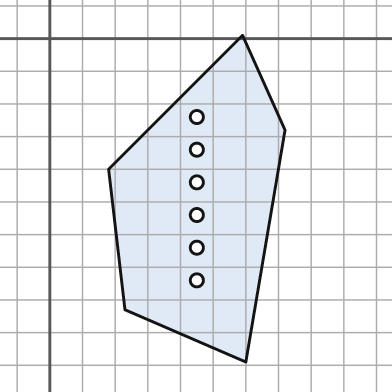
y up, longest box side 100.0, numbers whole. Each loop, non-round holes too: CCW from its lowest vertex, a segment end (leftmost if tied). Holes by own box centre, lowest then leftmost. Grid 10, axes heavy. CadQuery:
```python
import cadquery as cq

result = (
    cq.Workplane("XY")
    .moveTo(60.0, -99.0)
    .lineTo(72.0, -28.0)
    .lineTo(59.0, 1.0)
    .lineTo(18.0, -40.0)
    .lineTo(23.0, -83.0)
    .close()
    .moveTo(45.0, -74.0)
    .circle(2.0)
    .moveTo(45.0, -64.0)
    .circle(2.0)
    .moveTo(45.0, -54.0)
    .circle(2.0)
    .moveTo(45.0, -44.0)
    .circle(2.0)
    .moveTo(45.0, -34.0)
    .circle(2.0)
    .moveTo(45.0, -24.0)
    .circle(2.0)
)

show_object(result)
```